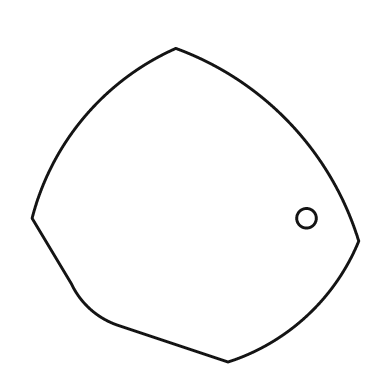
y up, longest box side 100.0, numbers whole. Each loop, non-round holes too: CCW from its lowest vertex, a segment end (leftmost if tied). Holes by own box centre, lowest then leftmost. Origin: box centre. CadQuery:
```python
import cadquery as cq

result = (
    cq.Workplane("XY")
    .moveTo(10.0, -48.0)
    .threePointArc((34.0, -34.0), (50.0, -11.0))
    .threePointArc((29.0, 25.0), (-6.0, 48.0))
    .threePointArc((-34.0, 27.0), (-50.0, -4.0))
    .lineTo(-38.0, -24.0)
    .threePointArc((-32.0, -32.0), (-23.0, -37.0))
    .close()
    .moveTo(34.0, -4.0)
    .circle(3.0)
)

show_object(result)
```